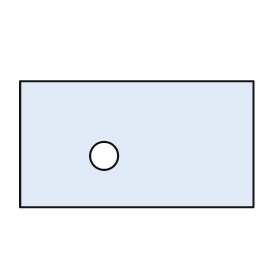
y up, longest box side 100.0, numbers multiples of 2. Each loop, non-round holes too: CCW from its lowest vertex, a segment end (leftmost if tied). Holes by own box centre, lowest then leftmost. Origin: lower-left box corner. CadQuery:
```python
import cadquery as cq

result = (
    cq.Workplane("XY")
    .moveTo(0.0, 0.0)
    .lineTo(100.0, 0.0)
    .lineTo(100.0, 54.0)
    .lineTo(0.0, 54.0)
    .close()
    .moveTo(36.0, 22.0)
    .circle(6.0)
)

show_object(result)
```